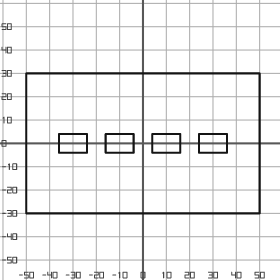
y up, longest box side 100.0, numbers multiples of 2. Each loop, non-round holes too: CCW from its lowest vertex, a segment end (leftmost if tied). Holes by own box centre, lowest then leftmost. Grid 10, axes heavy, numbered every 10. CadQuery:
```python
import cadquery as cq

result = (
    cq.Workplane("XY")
    .moveTo(-50.0, -30.0)
    .lineTo(50.0, -30.0)
    .lineTo(50.0, 30.0)
    .lineTo(-50.0, 30.0)
    .close()
    .moveTo(-36.0, -4.0)
    .lineTo(-24.0, -4.0)
    .lineTo(-24.0, 4.0)
    .lineTo(-36.0, 4.0)
    .close()
    .moveTo(-16.0, -4.0)
    .lineTo(-4.0, -4.0)
    .lineTo(-4.0, 4.0)
    .lineTo(-16.0, 4.0)
    .close()
    .moveTo(4.0, -4.0)
    .lineTo(16.0, -4.0)
    .lineTo(16.0, 4.0)
    .lineTo(4.0, 4.0)
    .close()
    .moveTo(24.0, -4.0)
    .lineTo(36.0, -4.0)
    .lineTo(36.0, 4.0)
    .lineTo(24.0, 4.0)
    .close()
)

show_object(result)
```